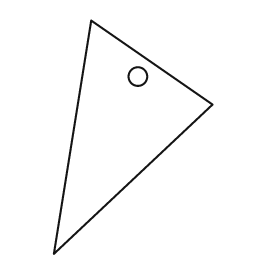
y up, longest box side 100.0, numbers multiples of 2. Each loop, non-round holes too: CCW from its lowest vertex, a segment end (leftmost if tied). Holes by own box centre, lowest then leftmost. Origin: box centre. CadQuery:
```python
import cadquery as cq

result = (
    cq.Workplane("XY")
    .moveTo(-34.0, -50.0)
    .lineTo(34.0, 14.0)
    .lineTo(-18.0, 50.0)
    .close()
    .moveTo(2.0, 26.0)
    .circle(4.0)
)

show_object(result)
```